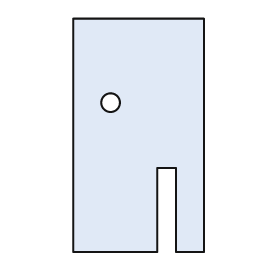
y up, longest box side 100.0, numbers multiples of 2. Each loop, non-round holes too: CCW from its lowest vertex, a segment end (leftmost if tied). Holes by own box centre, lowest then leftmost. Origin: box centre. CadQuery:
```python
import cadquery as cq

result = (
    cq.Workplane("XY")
    .moveTo(-28.0, -50.0)
    .lineTo(8.0, -50.0)
    .lineTo(8.0, -14.0)
    .lineTo(16.0, -14.0)
    .lineTo(16.0, -50.0)
    .lineTo(28.0, -50.0)
    .lineTo(28.0, 50.0)
    .lineTo(-28.0, 50.0)
    .close()
    .moveTo(-12.0, 14.0)
    .circle(4.0)
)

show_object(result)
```